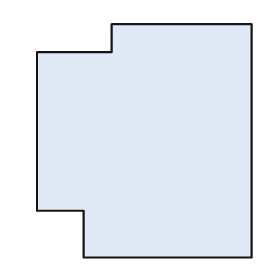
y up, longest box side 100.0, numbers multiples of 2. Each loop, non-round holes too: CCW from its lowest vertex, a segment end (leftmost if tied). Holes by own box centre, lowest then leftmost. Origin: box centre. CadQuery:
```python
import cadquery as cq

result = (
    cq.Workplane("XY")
    .moveTo(-26.0, -50.0)
    .lineTo(46.0, -50.0)
    .lineTo(46.0, 50.0)
    .lineTo(-14.0, 50.0)
    .lineTo(-14.0, 38.0)
    .lineTo(-46.0, 38.0)
    .lineTo(-46.0, -30.0)
    .lineTo(-26.0, -30.0)
    .close()
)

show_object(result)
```